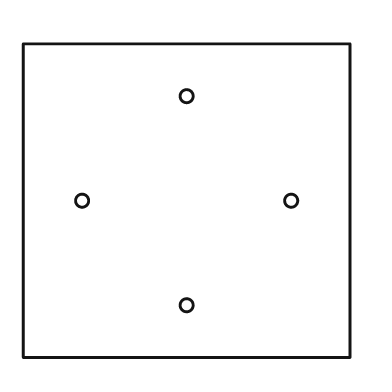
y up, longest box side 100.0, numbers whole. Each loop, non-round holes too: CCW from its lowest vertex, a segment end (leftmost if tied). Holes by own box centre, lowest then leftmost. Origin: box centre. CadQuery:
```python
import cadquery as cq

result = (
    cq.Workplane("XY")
    .moveTo(-50.0, -48.0)
    .lineTo(50.0, -48.0)
    .lineTo(50.0, 48.0)
    .lineTo(-50.0, 48.0)
    .close()
    .moveTo(0.0, -32.0)
    .circle(2.0)
    .moveTo(-32.0, 0.0)
    .circle(2.0)
    .moveTo(32.0, 0.0)
    .circle(2.0)
    .moveTo(0.0, 32.0)
    .circle(2.0)
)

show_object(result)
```